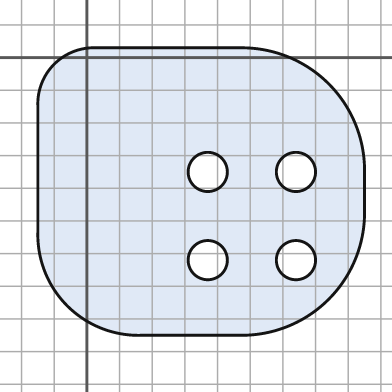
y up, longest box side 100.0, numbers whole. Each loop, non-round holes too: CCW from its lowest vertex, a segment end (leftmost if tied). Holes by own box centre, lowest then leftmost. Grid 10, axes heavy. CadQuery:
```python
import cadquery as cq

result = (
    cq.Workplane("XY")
    .moveTo(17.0, -85.0)
    .lineTo(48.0, -85.0)
    .threePointArc((74.0, -74.0), (85.0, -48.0))
    .lineTo(85.0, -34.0)
    .threePointArc((74.0, -8.0), (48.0, 3.0))
    .lineTo(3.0, 3.0)
    .threePointArc((-10.0, -2.0), (-15.0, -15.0))
    .lineTo(-15.0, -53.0)
    .threePointArc((-6.0, -76.0), (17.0, -85.0))
    .close()
    .moveTo(37.0, -62.0)
    .circle(6.0)
    .moveTo(64.0, -62.0)
    .circle(6.0)
    .moveTo(37.0, -35.0)
    .circle(6.0)
    .moveTo(64.0, -35.0)
    .circle(6.0)
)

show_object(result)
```